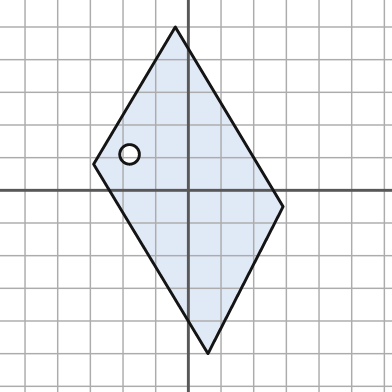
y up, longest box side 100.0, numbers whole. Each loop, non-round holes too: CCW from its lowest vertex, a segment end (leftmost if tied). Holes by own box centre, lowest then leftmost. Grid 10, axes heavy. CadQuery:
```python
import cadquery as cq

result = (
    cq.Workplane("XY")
    .moveTo(6.0, -50.0)
    .lineTo(29.0, -5.0)
    .lineTo(-4.0, 50.0)
    .lineTo(-29.0, 8.0)
    .close()
    .moveTo(-18.0, 11.0)
    .circle(3.0)
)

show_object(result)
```